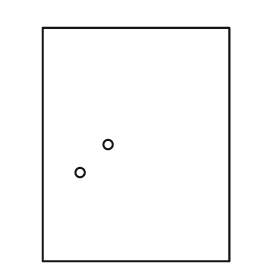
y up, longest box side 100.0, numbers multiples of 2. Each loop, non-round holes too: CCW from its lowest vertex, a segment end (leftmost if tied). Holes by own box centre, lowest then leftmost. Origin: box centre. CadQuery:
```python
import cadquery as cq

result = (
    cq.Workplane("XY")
    .moveTo(-40.0, -50.0)
    .lineTo(40.0, -50.0)
    .lineTo(40.0, 50.0)
    .lineTo(-40.0, 50.0)
    .close()
    .moveTo(-24.0, -12.0)
    .circle(2.0)
    .moveTo(-12.0, 0.0)
    .circle(2.0)
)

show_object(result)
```